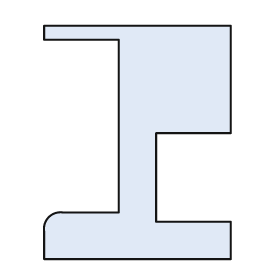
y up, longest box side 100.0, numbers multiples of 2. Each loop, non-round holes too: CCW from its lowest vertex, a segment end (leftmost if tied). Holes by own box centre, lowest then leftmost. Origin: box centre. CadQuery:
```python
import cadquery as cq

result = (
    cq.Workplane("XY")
    .moveTo(-40.0, -50.0)
    .lineTo(40.0, -50.0)
    .lineTo(40.0, -34.0)
    .lineTo(8.0, -34.0)
    .lineTo(8.0, 4.0)
    .lineTo(40.0, 4.0)
    .lineTo(40.0, 50.0)
    .lineTo(-40.0, 50.0)
    .lineTo(-40.0, 44.0)
    .lineTo(-8.0, 44.0)
    .lineTo(-8.0, -30.0)
    .lineTo(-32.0, -30.0)
    .threePointArc((-38.0, -32.0), (-40.0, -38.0))
    .close()
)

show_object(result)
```